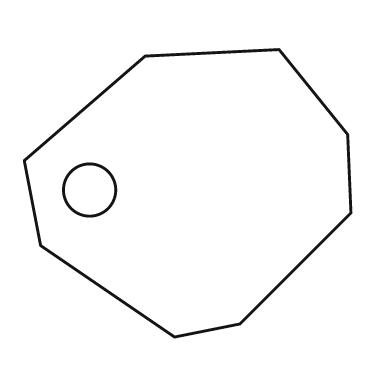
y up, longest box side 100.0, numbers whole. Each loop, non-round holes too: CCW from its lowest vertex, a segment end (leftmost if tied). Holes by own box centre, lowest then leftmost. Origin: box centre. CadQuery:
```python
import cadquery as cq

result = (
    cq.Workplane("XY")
    .moveTo(-4.0, -44.0)
    .lineTo(16.0, -40.0)
    .lineTo(50.0, -6.0)
    .lineTo(49.0, 18.0)
    .lineTo(28.0, 44.0)
    .lineTo(-13.0, 42.0)
    .lineTo(-50.0, 10.0)
    .lineTo(-45.0, -16.0)
    .close()
    .moveTo(-30.0, 1.0)
    .circle(8.0)
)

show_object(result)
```